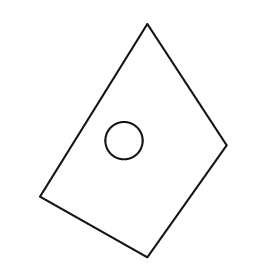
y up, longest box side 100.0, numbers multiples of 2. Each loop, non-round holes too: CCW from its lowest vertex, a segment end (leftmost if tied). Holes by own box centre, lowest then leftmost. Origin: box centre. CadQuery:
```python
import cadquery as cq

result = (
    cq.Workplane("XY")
    .moveTo(6.0, -50.0)
    .lineTo(40.0, -2.0)
    .lineTo(6.0, 50.0)
    .lineTo(-40.0, -24.0)
    .close()
    .moveTo(-4.0, 0.0)
    .circle(8.0)
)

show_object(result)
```